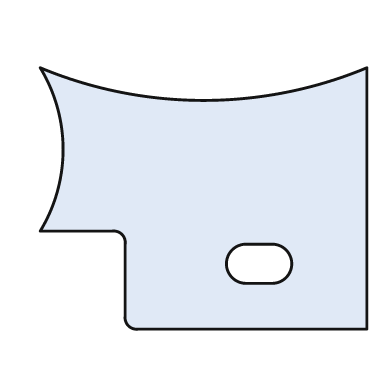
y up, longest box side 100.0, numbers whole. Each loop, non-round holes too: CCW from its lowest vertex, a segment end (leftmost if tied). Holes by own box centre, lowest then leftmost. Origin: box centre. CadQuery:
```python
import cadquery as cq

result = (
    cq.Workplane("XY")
    .moveTo(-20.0, -40.0)
    .lineTo(50.0, -40.0)
    .lineTo(50.0, 40.0)
    .threePointArc((0.0, 30.0), (-50.0, 40.0))
    .threePointArc((-43.0, 15.0), (-50.0, -10.0))
    .lineTo(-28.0, -10.0)
    .threePointArc((-25.0, -11.0), (-24.0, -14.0))
    .lineTo(-24.0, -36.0)
    .threePointArc((-23.0, -39.0), (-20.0, -40.0))
    .close()
    .moveTo(13.0, -26.0)
    .lineTo(21.0, -26.0)
    .threePointArc((27.0, -20.0), (21.0, -14.0))
    .lineTo(13.0, -14.0)
    .threePointArc((7.0, -20.0), (13.0, -26.0))
    .close()
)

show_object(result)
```